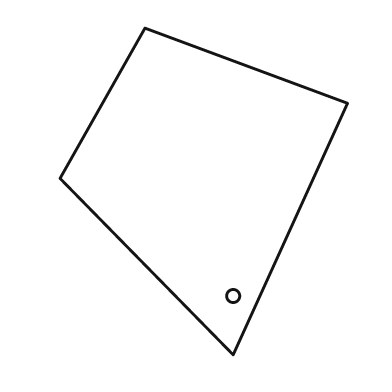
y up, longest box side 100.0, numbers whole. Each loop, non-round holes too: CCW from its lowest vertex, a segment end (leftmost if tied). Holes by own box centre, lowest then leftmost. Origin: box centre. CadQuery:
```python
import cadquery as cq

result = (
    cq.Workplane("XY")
    .moveTo(9.0, -50.0)
    .lineTo(44.0, 27.0)
    .lineTo(-18.0, 50.0)
    .lineTo(-44.0, 4.0)
    .close()
    .moveTo(9.0, -32.0)
    .circle(2.0)
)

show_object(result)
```